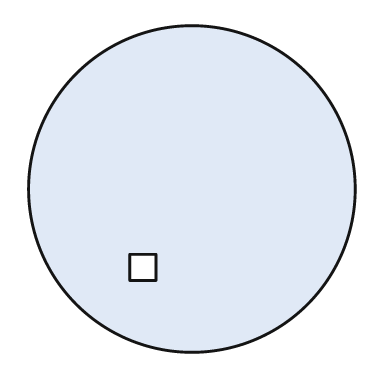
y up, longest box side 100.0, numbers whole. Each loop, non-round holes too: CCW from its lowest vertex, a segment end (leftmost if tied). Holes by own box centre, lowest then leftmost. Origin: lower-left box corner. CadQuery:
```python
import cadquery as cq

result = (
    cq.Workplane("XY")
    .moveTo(50.0, 50.0)
    .circle(50.0)
    .moveTo(31.0, 22.0)
    .lineTo(39.0, 22.0)
    .lineTo(39.0, 30.0)
    .lineTo(31.0, 30.0)
    .close()
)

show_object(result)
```